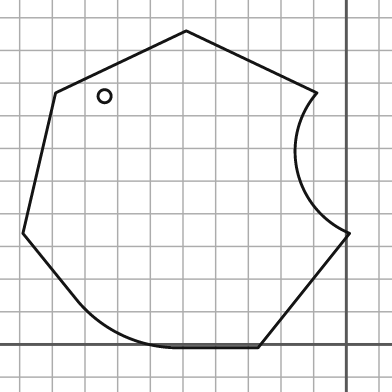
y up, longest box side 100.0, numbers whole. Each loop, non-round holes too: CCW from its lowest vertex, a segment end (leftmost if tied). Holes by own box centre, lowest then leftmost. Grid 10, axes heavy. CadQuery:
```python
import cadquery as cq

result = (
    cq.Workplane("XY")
    .moveTo(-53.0, -1.0)
    .lineTo(-27.0, -1.0)
    .lineTo(1.0, 34.0)
    .threePointArc((-15.0, 53.0), (-9.0, 77.0))
    .lineTo(-49.0, 96.0)
    .lineTo(-89.0, 77.0)
    .lineTo(-99.0, 34.0)
    .lineTo(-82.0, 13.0)
    .threePointArc((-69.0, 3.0), (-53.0, -1.0))
    .close()
    .moveTo(-74.0, 76.0)
    .circle(2.0)
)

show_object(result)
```